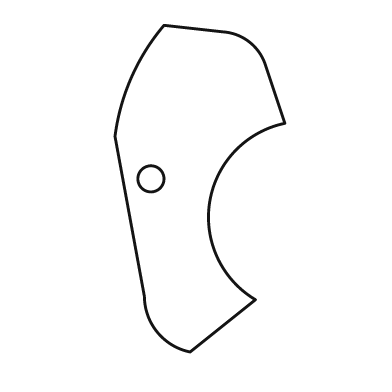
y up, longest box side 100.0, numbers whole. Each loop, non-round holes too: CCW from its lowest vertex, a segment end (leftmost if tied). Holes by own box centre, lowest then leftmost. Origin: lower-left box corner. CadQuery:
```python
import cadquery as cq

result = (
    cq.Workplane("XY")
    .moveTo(23.0, 0.0)
    .lineTo(43.0, 16.0)
    .threePointArc((29.0, 46.0), (52.0, 70.0))
    .lineTo(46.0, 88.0)
    .threePointArc((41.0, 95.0), (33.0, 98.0))
    .lineTo(15.0, 100.0)
    .threePointArc((5.0, 84.0), (0.0, 66.0))
    .lineTo(9.0, 17.0)
    .threePointArc((13.0, 6.0), (23.0, 0.0))
    .close()
    .moveTo(11.0, 53.0)
    .circle(4.0)
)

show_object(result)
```